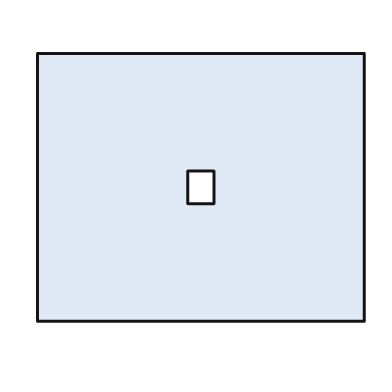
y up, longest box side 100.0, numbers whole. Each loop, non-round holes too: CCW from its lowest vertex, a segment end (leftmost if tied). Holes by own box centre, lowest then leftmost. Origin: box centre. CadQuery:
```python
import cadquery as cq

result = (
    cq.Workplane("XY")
    .moveTo(-50.0, -41.0)
    .lineTo(50.0, -41.0)
    .lineTo(50.0, 41.0)
    .lineTo(-50.0, 41.0)
    .close()
    .moveTo(-4.0, -5.0)
    .lineTo(4.0, -5.0)
    .lineTo(4.0, 5.0)
    .lineTo(-4.0, 5.0)
    .close()
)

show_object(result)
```